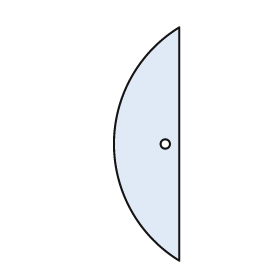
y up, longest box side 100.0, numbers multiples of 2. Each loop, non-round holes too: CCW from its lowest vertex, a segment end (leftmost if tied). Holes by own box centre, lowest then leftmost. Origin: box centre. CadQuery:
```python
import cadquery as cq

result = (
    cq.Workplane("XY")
    .moveTo(14.0, -50.0)
    .lineTo(14.0, 50.0)
    .threePointArc((-14.0, 0.0), (14.0, -50.0))
    .close()
    .moveTo(8.0, 0.0)
    .circle(2.0)
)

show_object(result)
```